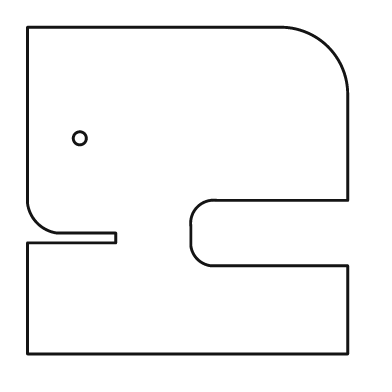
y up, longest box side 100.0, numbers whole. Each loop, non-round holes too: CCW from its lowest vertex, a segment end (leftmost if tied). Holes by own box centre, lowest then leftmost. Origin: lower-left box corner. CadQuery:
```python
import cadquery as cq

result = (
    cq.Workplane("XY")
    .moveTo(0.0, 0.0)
    .lineTo(98.0, 0.0)
    .lineTo(98.0, 27.0)
    .lineTo(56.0, 27.0)
    .threePointArc((52.0, 29.0), (50.0, 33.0))
    .lineTo(50.0, 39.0)
    .threePointArc((52.0, 45.0), (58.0, 47.0))
    .lineTo(98.0, 47.0)
    .lineTo(98.0, 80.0)
    .threePointArc((92.0, 94.0), (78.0, 100.0))
    .lineTo(0.0, 100.0)
    .lineTo(0.0, 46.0)
    .threePointArc((3.0, 40.0), (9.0, 37.0))
    .lineTo(27.0, 37.0)
    .lineTo(27.0, 34.0)
    .lineTo(0.0, 34.0)
    .close()
    .moveTo(16.0, 66.0)
    .circle(2.0)
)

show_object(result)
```